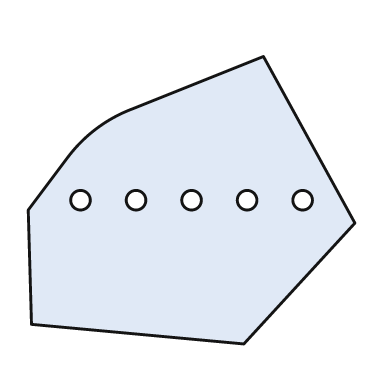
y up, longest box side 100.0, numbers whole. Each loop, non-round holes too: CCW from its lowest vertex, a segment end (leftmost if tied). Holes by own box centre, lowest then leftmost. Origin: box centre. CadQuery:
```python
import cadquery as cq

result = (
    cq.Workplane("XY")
    .moveTo(16.0, -44.0)
    .lineTo(50.0, -7.0)
    .lineTo(22.0, 44.0)
    .lineTo(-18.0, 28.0)
    .threePointArc((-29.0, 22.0), (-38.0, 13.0))
    .lineTo(-50.0, -3.0)
    .lineTo(-49.0, -38.0)
    .close()
    .moveTo(-34.0, 0.0)
    .circle(3.0)
    .moveTo(-17.0, 0.0)
    .circle(3.0)
    .moveTo(0.0, 0.0)
    .circle(3.0)
    .moveTo(17.0, 0.0)
    .circle(3.0)
    .moveTo(34.0, 0.0)
    .circle(3.0)
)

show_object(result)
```